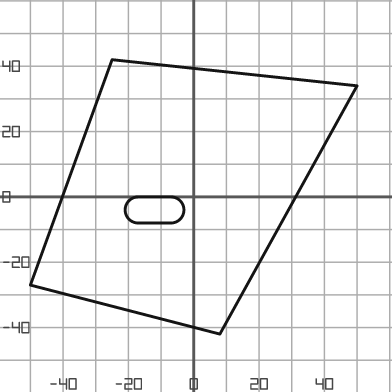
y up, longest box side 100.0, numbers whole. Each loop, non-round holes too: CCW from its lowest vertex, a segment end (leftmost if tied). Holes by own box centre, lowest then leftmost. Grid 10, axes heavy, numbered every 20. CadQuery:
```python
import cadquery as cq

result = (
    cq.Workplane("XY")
    .moveTo(8.0, -42.0)
    .lineTo(50.0, 34.0)
    .lineTo(-25.0, 42.0)
    .lineTo(-50.0, -27.0)
    .close()
    .moveTo(-17.0, -8.0)
    .lineTo(-7.0, -8.0)
    .threePointArc((-3.0, -4.0), (-7.0, 0.0))
    .lineTo(-17.0, 0.0)
    .threePointArc((-21.0, -4.0), (-17.0, -8.0))
    .close()
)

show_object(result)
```